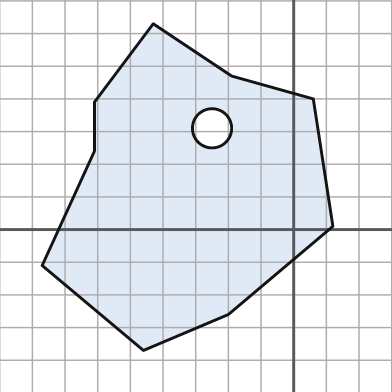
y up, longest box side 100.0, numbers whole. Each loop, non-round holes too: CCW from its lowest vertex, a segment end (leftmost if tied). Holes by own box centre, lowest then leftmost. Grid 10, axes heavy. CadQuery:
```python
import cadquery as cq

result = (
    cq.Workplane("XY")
    .moveTo(-46.0, -37.0)
    .lineTo(-20.0, -26.0)
    .lineTo(12.0, 1.0)
    .lineTo(6.0, 40.0)
    .lineTo(-19.0, 47.0)
    .lineTo(-43.0, 63.0)
    .lineTo(-61.0, 39.0)
    .lineTo(-61.0, 24.0)
    .lineTo(-77.0, -11.0)
    .close()
    .moveTo(-25.0, 31.0)
    .circle(6.0)
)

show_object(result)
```